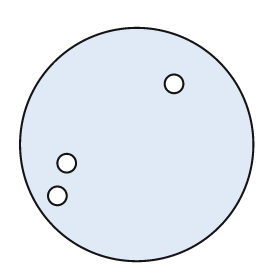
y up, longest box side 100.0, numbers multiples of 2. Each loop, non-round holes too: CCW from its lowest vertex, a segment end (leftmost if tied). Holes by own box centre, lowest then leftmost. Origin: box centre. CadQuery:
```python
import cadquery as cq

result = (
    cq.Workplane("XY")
    .moveTo(0.0, 0.0)
    .circle(50.0)
    .moveTo(-34.0, -22.0)
    .circle(4.0)
    .moveTo(-30.0, -8.0)
    .circle(4.0)
    .moveTo(16.0, 26.0)
    .circle(4.0)
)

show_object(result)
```